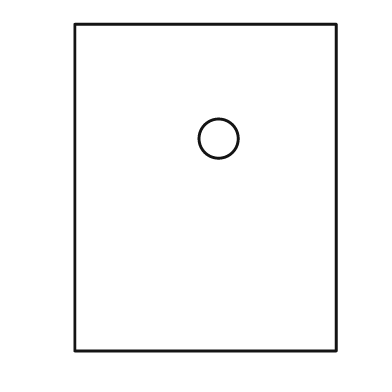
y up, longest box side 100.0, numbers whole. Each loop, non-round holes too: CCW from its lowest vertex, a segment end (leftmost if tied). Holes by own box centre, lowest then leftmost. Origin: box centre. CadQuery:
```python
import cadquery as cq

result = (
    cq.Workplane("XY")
    .moveTo(-40.0, -50.0)
    .lineTo(40.0, -50.0)
    .lineTo(40.0, 50.0)
    .lineTo(-40.0, 50.0)
    .close()
    .moveTo(4.0, 15.0)
    .circle(6.0)
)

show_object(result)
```